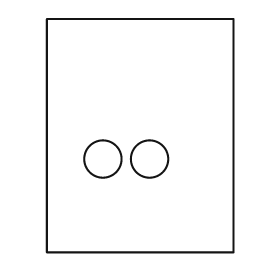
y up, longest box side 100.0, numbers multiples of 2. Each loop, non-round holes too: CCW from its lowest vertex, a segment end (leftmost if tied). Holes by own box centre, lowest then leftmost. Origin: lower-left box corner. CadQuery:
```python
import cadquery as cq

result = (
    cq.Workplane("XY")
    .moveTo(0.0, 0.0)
    .lineTo(80.0, 0.0)
    .lineTo(80.0, 100.0)
    .lineTo(0.0, 100.0)
    .close()
    .moveTo(24.0, 40.0)
    .circle(8.0)
    .moveTo(44.0, 40.0)
    .circle(8.0)
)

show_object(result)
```